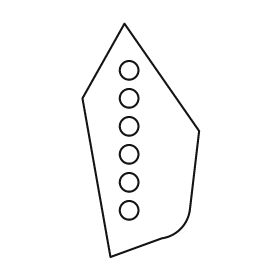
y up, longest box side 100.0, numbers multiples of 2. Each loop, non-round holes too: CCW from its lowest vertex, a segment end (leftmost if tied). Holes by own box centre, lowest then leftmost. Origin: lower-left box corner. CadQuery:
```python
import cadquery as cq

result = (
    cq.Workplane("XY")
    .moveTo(12.0, 0.0)
    .lineTo(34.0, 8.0)
    .threePointArc((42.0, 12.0), (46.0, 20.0))
    .lineTo(50.0, 54.0)
    .lineTo(18.0, 100.0)
    .lineTo(0.0, 68.0)
    .close()
    .moveTo(20.0, 20.0)
    .circle(4.0)
    .moveTo(20.0, 32.0)
    .circle(4.0)
    .moveTo(20.0, 44.0)
    .circle(4.0)
    .moveTo(20.0, 56.0)
    .circle(4.0)
    .moveTo(20.0, 68.0)
    .circle(4.0)
    .moveTo(20.0, 80.0)
    .circle(4.0)
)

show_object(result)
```